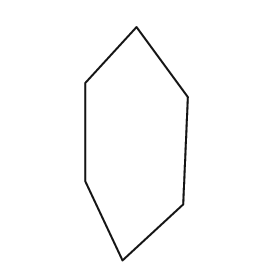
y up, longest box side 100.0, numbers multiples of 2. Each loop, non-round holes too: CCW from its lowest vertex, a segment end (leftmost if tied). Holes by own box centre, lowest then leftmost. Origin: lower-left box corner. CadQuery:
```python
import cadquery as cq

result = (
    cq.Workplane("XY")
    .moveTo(16.0, 0.0)
    .lineTo(42.0, 24.0)
    .lineTo(44.0, 70.0)
    .lineTo(22.0, 100.0)
    .lineTo(0.0, 76.0)
    .lineTo(0.0, 34.0)
    .close()
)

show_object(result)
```